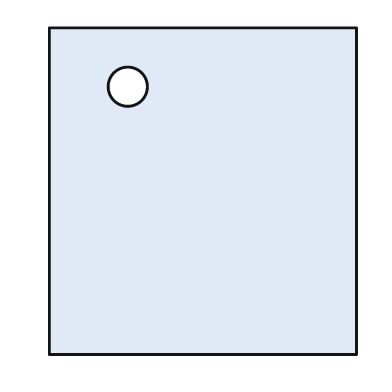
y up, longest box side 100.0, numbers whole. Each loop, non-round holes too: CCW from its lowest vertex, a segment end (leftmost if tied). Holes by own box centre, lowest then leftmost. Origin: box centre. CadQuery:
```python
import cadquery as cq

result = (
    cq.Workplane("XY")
    .moveTo(-47.0, -50.0)
    .lineTo(47.0, -50.0)
    .lineTo(47.0, 50.0)
    .lineTo(-47.0, 50.0)
    .close()
    .moveTo(-23.0, 32.0)
    .circle(6.0)
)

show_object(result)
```